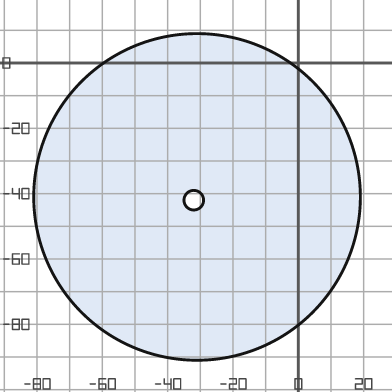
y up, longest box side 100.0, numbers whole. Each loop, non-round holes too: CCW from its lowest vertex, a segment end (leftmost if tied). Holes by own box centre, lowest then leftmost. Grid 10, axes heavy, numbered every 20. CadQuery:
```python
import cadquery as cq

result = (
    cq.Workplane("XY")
    .moveTo(-31.0, -41.0)
    .circle(50.0)
    .moveTo(-32.0, -42.0)
    .circle(3.0)
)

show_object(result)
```